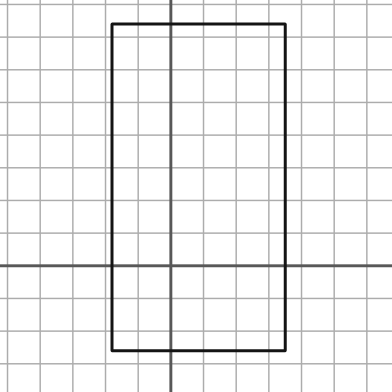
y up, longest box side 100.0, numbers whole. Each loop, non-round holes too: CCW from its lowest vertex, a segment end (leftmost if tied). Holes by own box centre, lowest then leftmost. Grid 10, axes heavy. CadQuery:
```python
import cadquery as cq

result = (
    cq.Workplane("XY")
    .moveTo(-18.0, -26.0)
    .lineTo(35.0, -26.0)
    .lineTo(35.0, 74.0)
    .lineTo(-18.0, 74.0)
    .close()
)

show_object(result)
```